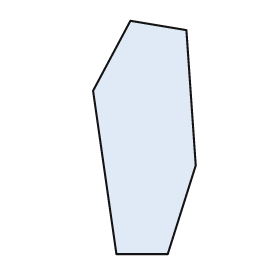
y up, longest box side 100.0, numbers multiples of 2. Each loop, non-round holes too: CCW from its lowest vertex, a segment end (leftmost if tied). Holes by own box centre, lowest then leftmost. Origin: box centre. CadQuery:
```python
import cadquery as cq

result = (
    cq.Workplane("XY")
    .moveTo(-12.0, -50.0)
    .lineTo(10.0, -50.0)
    .lineTo(22.0, -12.0)
    .lineTo(18.0, 46.0)
    .lineTo(-6.0, 50.0)
    .lineTo(-22.0, 20.0)
    .close()
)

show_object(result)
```